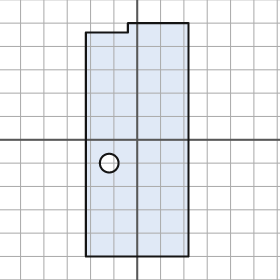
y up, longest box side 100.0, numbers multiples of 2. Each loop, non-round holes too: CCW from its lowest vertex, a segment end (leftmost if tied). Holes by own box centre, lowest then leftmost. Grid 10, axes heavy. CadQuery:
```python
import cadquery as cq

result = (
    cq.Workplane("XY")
    .moveTo(-22.0, -50.0)
    .lineTo(22.0, -50.0)
    .lineTo(22.0, 50.0)
    .lineTo(-4.0, 50.0)
    .lineTo(-4.0, 46.0)
    .lineTo(-22.0, 46.0)
    .close()
    .moveTo(-12.0, -10.0)
    .circle(4.0)
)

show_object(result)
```